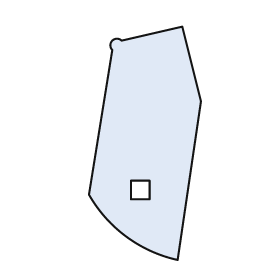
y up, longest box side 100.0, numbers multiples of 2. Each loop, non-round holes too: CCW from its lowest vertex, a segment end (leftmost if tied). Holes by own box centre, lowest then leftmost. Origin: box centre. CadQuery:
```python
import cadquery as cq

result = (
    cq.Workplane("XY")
    .moveTo(14.0, -50.0)
    .lineTo(24.0, 18.0)
    .lineTo(16.0, 50.0)
    .lineTo(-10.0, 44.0)
    .threePointArc((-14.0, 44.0), (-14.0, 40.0))
    .lineTo(-24.0, -22.0)
    .threePointArc((-8.0, -40.0), (14.0, -50.0))
    .close()
    .moveTo(-6.0, -24.0)
    .lineTo(2.0, -24.0)
    .lineTo(2.0, -16.0)
    .lineTo(-6.0, -16.0)
    .close()
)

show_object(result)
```